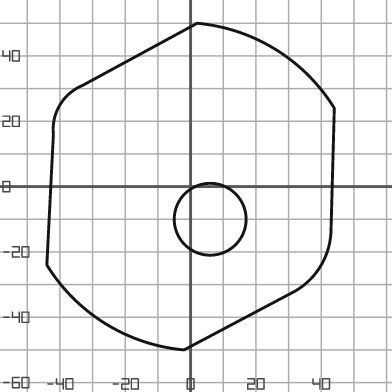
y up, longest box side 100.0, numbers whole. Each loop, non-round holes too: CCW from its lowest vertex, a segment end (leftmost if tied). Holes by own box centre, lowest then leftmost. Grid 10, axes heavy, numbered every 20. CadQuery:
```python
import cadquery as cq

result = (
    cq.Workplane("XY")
    .moveTo(-2.0, -50.0)
    .lineTo(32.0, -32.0)
    .threePointArc((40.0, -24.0), (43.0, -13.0))
    .lineTo(44.0, 24.0)
    .threePointArc((26.0, 42.0), (2.0, 50.0))
    .lineTo(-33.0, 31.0)
    .threePointArc((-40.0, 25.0), (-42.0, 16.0))
    .lineTo(-44.0, -24.0)
    .threePointArc((-26.0, -42.0), (-2.0, -50.0))
    .close()
    .moveTo(6.0, -10.0)
    .circle(11.0)
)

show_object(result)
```